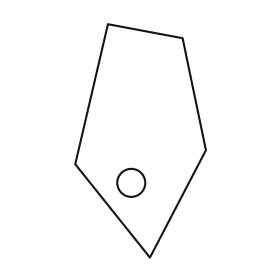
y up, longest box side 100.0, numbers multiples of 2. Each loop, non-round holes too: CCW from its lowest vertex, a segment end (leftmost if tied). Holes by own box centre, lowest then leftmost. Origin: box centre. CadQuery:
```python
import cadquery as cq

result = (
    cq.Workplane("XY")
    .moveTo(4.0, -50.0)
    .lineTo(28.0, -4.0)
    .lineTo(18.0, 44.0)
    .lineTo(-14.0, 50.0)
    .lineTo(-28.0, -10.0)
    .close()
    .moveTo(-4.0, -18.0)
    .circle(6.0)
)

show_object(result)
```